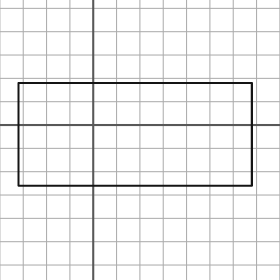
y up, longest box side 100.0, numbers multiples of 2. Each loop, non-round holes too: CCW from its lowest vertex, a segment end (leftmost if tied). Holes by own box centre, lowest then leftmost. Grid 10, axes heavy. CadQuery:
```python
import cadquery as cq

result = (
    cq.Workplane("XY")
    .moveTo(-32.0, -26.0)
    .lineTo(68.0, -26.0)
    .lineTo(68.0, 18.0)
    .lineTo(-32.0, 18.0)
    .close()
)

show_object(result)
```